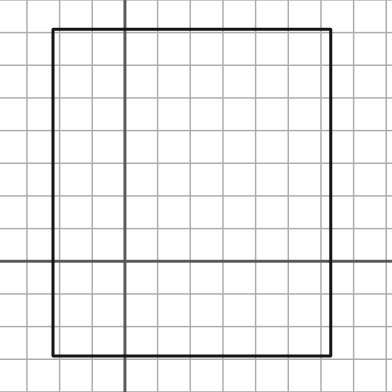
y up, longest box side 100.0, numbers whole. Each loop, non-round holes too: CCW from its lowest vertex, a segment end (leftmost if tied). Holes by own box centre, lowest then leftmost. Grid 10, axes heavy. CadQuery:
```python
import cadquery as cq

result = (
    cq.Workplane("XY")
    .moveTo(-22.0, -29.0)
    .lineTo(63.0, -29.0)
    .lineTo(63.0, 71.0)
    .lineTo(-22.0, 71.0)
    .close()
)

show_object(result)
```